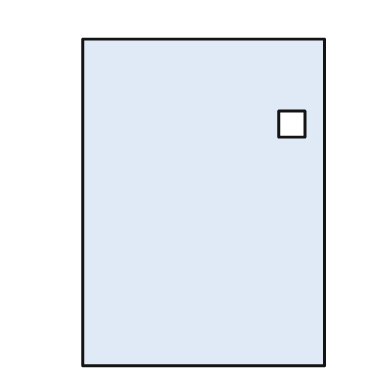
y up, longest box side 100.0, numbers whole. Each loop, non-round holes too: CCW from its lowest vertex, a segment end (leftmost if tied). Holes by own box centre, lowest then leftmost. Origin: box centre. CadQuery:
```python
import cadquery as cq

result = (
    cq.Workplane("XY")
    .moveTo(-37.0, -50.0)
    .lineTo(37.0, -50.0)
    .lineTo(37.0, 50.0)
    .lineTo(-37.0, 50.0)
    .close()
    .moveTo(23.0, 20.0)
    .lineTo(31.0, 20.0)
    .lineTo(31.0, 28.0)
    .lineTo(23.0, 28.0)
    .close()
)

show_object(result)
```